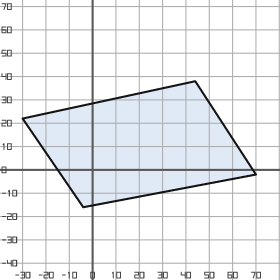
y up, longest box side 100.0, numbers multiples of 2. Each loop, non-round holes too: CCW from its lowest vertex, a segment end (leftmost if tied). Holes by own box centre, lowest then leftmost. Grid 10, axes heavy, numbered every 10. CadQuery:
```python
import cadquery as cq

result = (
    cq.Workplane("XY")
    .moveTo(-4.0, -16.0)
    .lineTo(70.0, -2.0)
    .lineTo(44.0, 38.0)
    .lineTo(-30.0, 22.0)
    .close()
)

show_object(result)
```